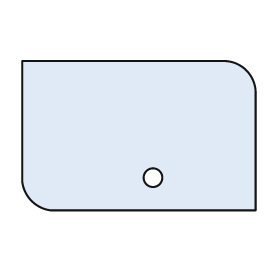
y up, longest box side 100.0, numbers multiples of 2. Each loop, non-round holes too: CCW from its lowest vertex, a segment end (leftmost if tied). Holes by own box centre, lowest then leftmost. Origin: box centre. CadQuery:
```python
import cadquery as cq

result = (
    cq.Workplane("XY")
    .moveTo(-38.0, -32.0)
    .lineTo(50.0, -32.0)
    .lineTo(50.0, 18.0)
    .threePointArc((46.0, 28.0), (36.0, 32.0))
    .lineTo(-50.0, 32.0)
    .lineTo(-50.0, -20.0)
    .threePointArc((-46.0, -28.0), (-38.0, -32.0))
    .close()
    .moveTo(6.0, -18.0)
    .circle(4.0)
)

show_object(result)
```